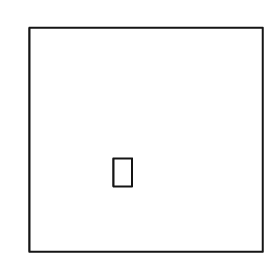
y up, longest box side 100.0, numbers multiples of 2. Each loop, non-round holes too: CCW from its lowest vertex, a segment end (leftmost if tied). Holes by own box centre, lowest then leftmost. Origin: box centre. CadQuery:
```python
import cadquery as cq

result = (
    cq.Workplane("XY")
    .moveTo(-50.0, -48.0)
    .lineTo(50.0, -48.0)
    .lineTo(50.0, 48.0)
    .lineTo(-50.0, 48.0)
    .close()
    .moveTo(-14.0, -20.0)
    .lineTo(-6.0, -20.0)
    .lineTo(-6.0, -8.0)
    .lineTo(-14.0, -8.0)
    .close()
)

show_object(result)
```